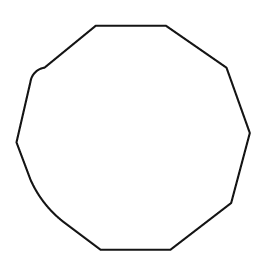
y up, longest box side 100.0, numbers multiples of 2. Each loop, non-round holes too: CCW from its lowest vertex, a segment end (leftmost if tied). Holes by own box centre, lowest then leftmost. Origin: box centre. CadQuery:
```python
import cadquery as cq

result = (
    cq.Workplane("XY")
    .moveTo(-14.0, -48.0)
    .lineTo(16.0, -48.0)
    .lineTo(42.0, -28.0)
    .lineTo(50.0, 2.0)
    .lineTo(40.0, 30.0)
    .lineTo(14.0, 48.0)
    .lineTo(-16.0, 48.0)
    .lineTo(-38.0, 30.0)
    .threePointArc((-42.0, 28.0), (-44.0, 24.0))
    .lineTo(-50.0, -2.0)
    .lineTo(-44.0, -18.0)
    .threePointArc((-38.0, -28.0), (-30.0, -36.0))
    .close()
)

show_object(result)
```